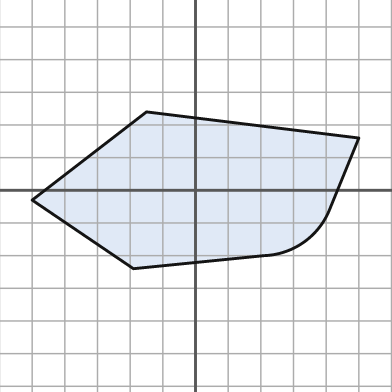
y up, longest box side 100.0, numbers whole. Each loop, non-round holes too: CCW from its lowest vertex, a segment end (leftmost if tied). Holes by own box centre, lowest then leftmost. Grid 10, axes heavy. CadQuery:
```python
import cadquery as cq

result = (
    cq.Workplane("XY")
    .moveTo(-19.0, -24.0)
    .lineTo(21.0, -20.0)
    .threePointArc((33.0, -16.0), (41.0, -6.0))
    .lineTo(50.0, 16.0)
    .lineTo(-15.0, 24.0)
    .lineTo(-50.0, -3.0)
    .close()
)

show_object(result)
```